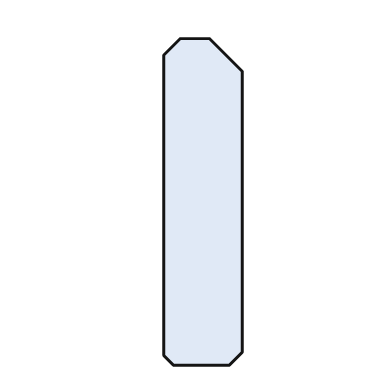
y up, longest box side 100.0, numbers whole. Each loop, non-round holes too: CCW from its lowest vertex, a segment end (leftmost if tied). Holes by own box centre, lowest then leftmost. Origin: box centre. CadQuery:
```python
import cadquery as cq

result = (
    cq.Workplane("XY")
    .moveTo(-9.0, -50.0)
    .lineTo(8.0, -50.0)
    .lineTo(12.0, -46.0)
    .lineTo(12.0, 40.0)
    .lineTo(2.0, 50.0)
    .lineTo(-7.0, 50.0)
    .lineTo(-12.0, 45.0)
    .lineTo(-12.0, -47.0)
    .close()
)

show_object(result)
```